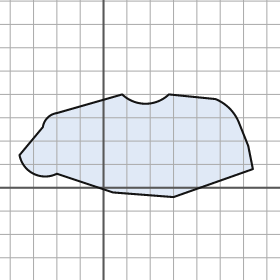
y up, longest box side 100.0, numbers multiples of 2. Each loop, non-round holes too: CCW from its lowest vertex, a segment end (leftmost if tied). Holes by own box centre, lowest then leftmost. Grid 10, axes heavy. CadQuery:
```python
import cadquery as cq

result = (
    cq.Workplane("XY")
    .moveTo(30.0, -4.0)
    .lineTo(64.0, 8.0)
    .lineTo(62.0, 18.0)
    .lineTo(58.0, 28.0)
    .threePointArc((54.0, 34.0), (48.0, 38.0))
    .lineTo(28.0, 40.0)
    .threePointArc((18.0, 36.0), (8.0, 40.0))
    .lineTo(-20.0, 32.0)
    .threePointArc((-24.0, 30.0), (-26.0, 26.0))
    .lineTo(-36.0, 14.0)
    .threePointArc((-30.0, 6.0), (-20.0, 6.0))
    .lineTo(4.0, -2.0)
    .close()
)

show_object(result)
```